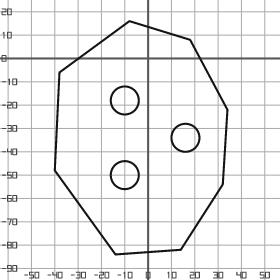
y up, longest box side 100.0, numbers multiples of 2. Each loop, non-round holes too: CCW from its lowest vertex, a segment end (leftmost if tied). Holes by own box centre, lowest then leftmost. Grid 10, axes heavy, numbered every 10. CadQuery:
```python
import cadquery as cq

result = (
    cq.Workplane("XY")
    .moveTo(-14.0, -84.0)
    .lineTo(14.0, -82.0)
    .lineTo(32.0, -54.0)
    .lineTo(34.0, -22.0)
    .lineTo(18.0, 8.0)
    .lineTo(-8.0, 16.0)
    .lineTo(-38.0, -6.0)
    .lineTo(-40.0, -48.0)
    .close()
    .moveTo(-10.0, -50.0)
    .circle(6.0)
    .moveTo(16.0, -34.0)
    .circle(6.0)
    .moveTo(-10.0, -18.0)
    .circle(6.0)
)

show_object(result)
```